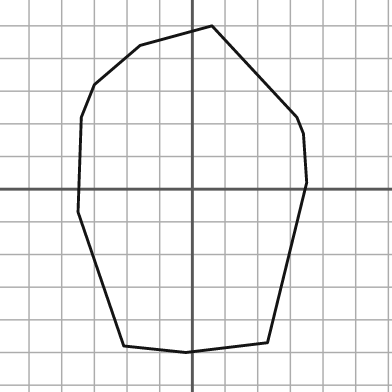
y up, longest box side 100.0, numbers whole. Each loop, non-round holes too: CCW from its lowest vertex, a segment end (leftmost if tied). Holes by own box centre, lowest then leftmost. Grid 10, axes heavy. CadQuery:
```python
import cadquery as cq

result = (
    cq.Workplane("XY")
    .moveTo(-2.0, -50.0)
    .lineTo(23.0, -47.0)
    .lineTo(35.0, 2.0)
    .lineTo(34.0, 17.0)
    .lineTo(32.0, 22.0)
    .lineTo(6.0, 50.0)
    .lineTo(-16.0, 44.0)
    .lineTo(-30.0, 32.0)
    .lineTo(-34.0, 22.0)
    .lineTo(-35.0, -7.0)
    .lineTo(-21.0, -48.0)
    .close()
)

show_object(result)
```